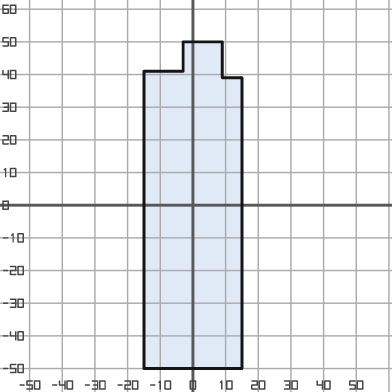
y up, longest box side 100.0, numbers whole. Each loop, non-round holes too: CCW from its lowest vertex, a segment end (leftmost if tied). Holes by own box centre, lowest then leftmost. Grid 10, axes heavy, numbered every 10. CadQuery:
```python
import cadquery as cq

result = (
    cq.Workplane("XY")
    .moveTo(-15.0, -50.0)
    .lineTo(15.0, -50.0)
    .lineTo(15.0, 39.0)
    .lineTo(9.0, 39.0)
    .lineTo(9.0, 50.0)
    .lineTo(-3.0, 50.0)
    .lineTo(-3.0, 41.0)
    .lineTo(-15.0, 41.0)
    .close()
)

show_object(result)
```